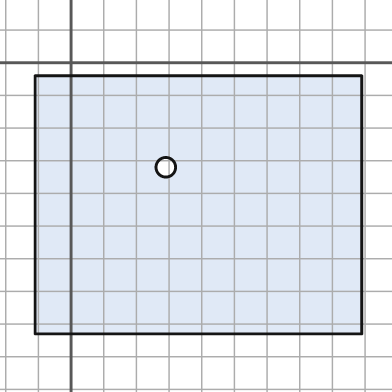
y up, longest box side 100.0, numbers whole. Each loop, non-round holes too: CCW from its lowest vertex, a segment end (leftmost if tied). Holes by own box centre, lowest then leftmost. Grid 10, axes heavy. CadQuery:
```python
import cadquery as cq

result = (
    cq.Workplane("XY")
    .moveTo(-11.0, -83.0)
    .lineTo(89.0, -83.0)
    .lineTo(89.0, -4.0)
    .lineTo(-11.0, -4.0)
    .close()
    .moveTo(29.0, -32.0)
    .circle(3.0)
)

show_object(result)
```